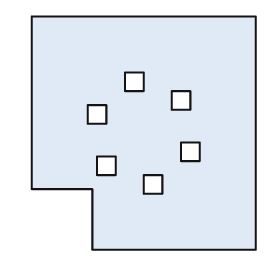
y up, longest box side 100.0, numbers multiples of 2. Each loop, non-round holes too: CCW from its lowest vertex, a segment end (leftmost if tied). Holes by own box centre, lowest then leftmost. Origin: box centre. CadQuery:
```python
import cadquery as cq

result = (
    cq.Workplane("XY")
    .moveTo(-22.0, -50.0)
    .lineTo(48.0, -50.0)
    .lineTo(48.0, 50.0)
    .lineTo(-48.0, 50.0)
    .lineTo(-48.0, -24.0)
    .lineTo(-22.0, -24.0)
    .close()
    .moveTo(0.0, -26.0)
    .lineTo(8.0, -26.0)
    .lineTo(8.0, -18.0)
    .lineTo(0.0, -18.0)
    .close()
    .moveTo(-20.0, -18.0)
    .lineTo(-12.0, -18.0)
    .lineTo(-12.0, -10.0)
    .lineTo(-20.0, -10.0)
    .close()
    .moveTo(16.0, -12.0)
    .lineTo(24.0, -12.0)
    .lineTo(24.0, -4.0)
    .lineTo(16.0, -4.0)
    .close()
    .moveTo(-24.0, 4.0)
    .lineTo(-16.0, 4.0)
    .lineTo(-16.0, 12.0)
    .lineTo(-24.0, 12.0)
    .close()
    .moveTo(12.0, 10.0)
    .lineTo(20.0, 10.0)
    .lineTo(20.0, 18.0)
    .lineTo(12.0, 18.0)
    .close()
    .moveTo(-8.0, 18.0)
    .lineTo(0.0, 18.0)
    .lineTo(0.0, 26.0)
    .lineTo(-8.0, 26.0)
    .close()
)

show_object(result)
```